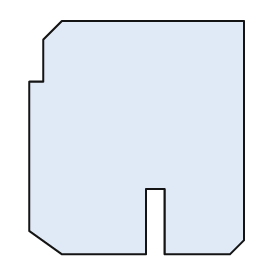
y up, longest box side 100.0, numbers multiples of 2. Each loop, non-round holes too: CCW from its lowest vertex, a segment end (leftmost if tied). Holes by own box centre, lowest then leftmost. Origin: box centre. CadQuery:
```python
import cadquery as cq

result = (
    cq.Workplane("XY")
    .moveTo(-32.0, -50.0)
    .lineTo(4.0, -50.0)
    .lineTo(4.0, -22.0)
    .lineTo(12.0, -22.0)
    .lineTo(12.0, -50.0)
    .lineTo(40.0, -50.0)
    .lineTo(46.0, -44.0)
    .lineTo(46.0, 50.0)
    .lineTo(-32.0, 50.0)
    .lineTo(-40.0, 42.0)
    .lineTo(-40.0, 24.0)
    .lineTo(-46.0, 24.0)
    .lineTo(-46.0, -40.0)
    .close()
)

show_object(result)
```